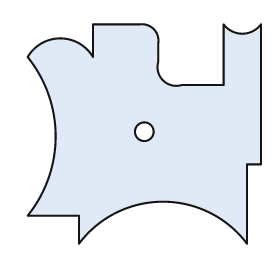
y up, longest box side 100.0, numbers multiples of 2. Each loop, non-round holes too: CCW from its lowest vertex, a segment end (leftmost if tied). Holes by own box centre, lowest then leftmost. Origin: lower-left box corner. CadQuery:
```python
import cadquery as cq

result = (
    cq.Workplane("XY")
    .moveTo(22.0, 0.0)
    .threePointArc((58.0, 18.0), (94.0, 0.0))
    .lineTo(94.0, 34.0)
    .lineTo(100.0, 34.0)
    .lineTo(100.0, 94.0)
    .threePointArc((92.0, 90.0), (84.0, 94.0))
    .lineTo(84.0, 68.0)
    .lineTo(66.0, 68.0)
    .threePointArc((58.0, 70.0), (56.0, 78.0))
    .lineTo(56.0, 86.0)
    .threePointArc((54.0, 92.0), (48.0, 94.0))
    .lineTo(28.0, 94.0)
    .lineTo(28.0, 80.0)
    .threePointArc((14.0, 88.0), (0.0, 80.0))
    .threePointArc((12.0, 46.0), (0.0, 12.0))
    .lineTo(22.0, 12.0)
    .close()
    .moveTo(50.0, 48.0)
    .circle(4.0)
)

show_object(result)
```